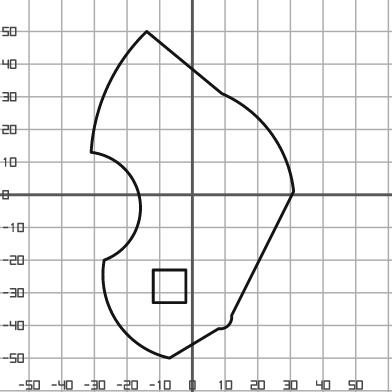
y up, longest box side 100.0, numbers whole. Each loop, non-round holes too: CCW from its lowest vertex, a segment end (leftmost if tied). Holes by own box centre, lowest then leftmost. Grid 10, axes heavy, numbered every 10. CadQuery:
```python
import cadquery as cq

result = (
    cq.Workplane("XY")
    .moveTo(-7.0, -50.0)
    .lineTo(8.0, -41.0)
    .threePointArc((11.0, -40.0), (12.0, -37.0))
    .lineTo(31.0, 1.0)
    .threePointArc((24.0, 19.0), (9.0, 31.0))
    .lineTo(-14.0, 50.0)
    .threePointArc((-26.0, 33.0), (-31.0, 13.0))
    .threePointArc((-16.0, -2.0), (-27.0, -20.0))
    .threePointArc((-23.0, -39.0), (-7.0, -50.0))
    .close()
    .moveTo(-12.0, -33.0)
    .lineTo(-2.0, -33.0)
    .lineTo(-2.0, -23.0)
    .lineTo(-12.0, -23.0)
    .close()
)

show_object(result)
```